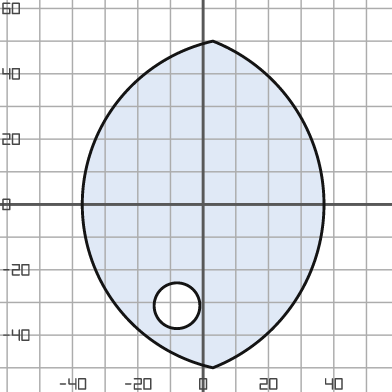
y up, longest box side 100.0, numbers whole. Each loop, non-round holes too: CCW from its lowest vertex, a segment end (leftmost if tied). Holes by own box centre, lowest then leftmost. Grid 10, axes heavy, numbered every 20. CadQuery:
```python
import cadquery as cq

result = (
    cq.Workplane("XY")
    .moveTo(3.0, -50.0)
    .threePointArc((37.0, 0.0), (3.0, 50.0))
    .threePointArc((-37.0, 0.0), (3.0, -50.0))
    .close()
    .moveTo(-8.0, -31.0)
    .circle(7.0)
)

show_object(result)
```